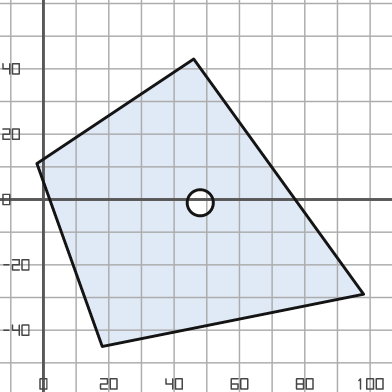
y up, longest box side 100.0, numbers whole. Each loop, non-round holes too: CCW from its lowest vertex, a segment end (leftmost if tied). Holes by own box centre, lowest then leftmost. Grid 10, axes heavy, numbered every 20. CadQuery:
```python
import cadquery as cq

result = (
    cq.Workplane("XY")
    .moveTo(18.0, -45.0)
    .lineTo(98.0, -29.0)
    .lineTo(46.0, 43.0)
    .lineTo(-2.0, 11.0)
    .close()
    .moveTo(48.0, -1.0)
    .circle(4.0)
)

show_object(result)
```